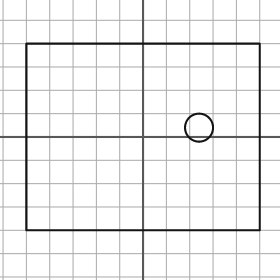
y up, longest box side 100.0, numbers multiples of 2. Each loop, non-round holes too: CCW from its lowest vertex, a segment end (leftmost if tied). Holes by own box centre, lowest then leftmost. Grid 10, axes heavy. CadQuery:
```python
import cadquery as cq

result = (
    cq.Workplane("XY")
    .moveTo(-50.0, -40.0)
    .lineTo(50.0, -40.0)
    .lineTo(50.0, 40.0)
    .lineTo(-50.0, 40.0)
    .close()
    .moveTo(24.0, 4.0)
    .circle(6.0)
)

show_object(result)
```